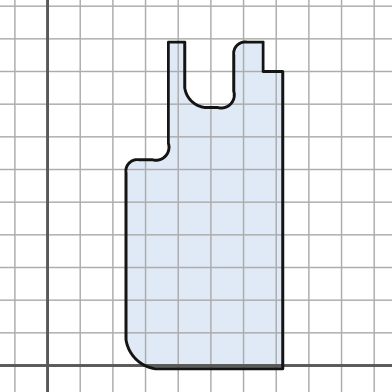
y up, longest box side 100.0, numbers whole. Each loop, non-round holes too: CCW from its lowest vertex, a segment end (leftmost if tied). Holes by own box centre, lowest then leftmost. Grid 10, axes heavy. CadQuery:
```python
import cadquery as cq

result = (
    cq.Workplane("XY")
    .moveTo(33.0, -1.0)
    .lineTo(72.0, -1.0)
    .lineTo(72.0, 90.0)
    .lineTo(66.0, 90.0)
    .lineTo(66.0, 99.0)
    .lineTo(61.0, 99.0)
    .threePointArc((58.0, 98.0), (57.0, 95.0))
    .lineTo(57.0, 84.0)
    .threePointArc((56.0, 80.0), (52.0, 79.0))
    .lineTo(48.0, 79.0)
    .threePointArc((44.0, 81.0), (42.0, 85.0))
    .lineTo(42.0, 99.0)
    .lineTo(37.0, 99.0)
    .lineTo(37.0, 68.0)
    .threePointArc((36.0, 64.0), (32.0, 63.0))
    .lineTo(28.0, 63.0)
    .threePointArc((25.0, 62.0), (24.0, 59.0))
    .lineTo(24.0, 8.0)
    .threePointArc((27.0, 2.0), (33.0, -1.0))
    .close()
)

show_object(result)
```